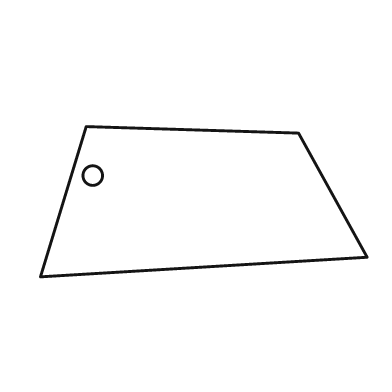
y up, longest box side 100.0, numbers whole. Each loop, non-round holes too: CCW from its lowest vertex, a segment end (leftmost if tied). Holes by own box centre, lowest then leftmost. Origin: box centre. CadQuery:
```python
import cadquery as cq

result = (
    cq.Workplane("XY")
    .moveTo(-50.0, -23.0)
    .lineTo(50.0, -17.0)
    .lineTo(29.0, 21.0)
    .lineTo(-36.0, 23.0)
    .close()
    .moveTo(-34.0, 8.0)
    .circle(3.0)
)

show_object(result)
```